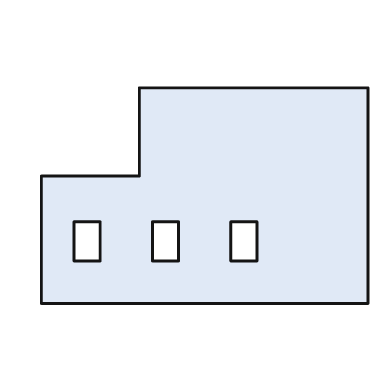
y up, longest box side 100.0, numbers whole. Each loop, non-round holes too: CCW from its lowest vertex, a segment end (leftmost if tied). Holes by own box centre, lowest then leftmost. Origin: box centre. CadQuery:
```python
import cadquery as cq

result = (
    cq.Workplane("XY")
    .moveTo(-50.0, -33.0)
    .lineTo(50.0, -33.0)
    .lineTo(50.0, 33.0)
    .lineTo(-20.0, 33.0)
    .lineTo(-20.0, 6.0)
    .lineTo(-50.0, 6.0)
    .close()
    .moveTo(-40.0, -20.0)
    .lineTo(-32.0, -20.0)
    .lineTo(-32.0, -8.0)
    .lineTo(-40.0, -8.0)
    .close()
    .moveTo(-16.0, -20.0)
    .lineTo(-8.0, -20.0)
    .lineTo(-8.0, -8.0)
    .lineTo(-16.0, -8.0)
    .close()
    .moveTo(8.0, -20.0)
    .lineTo(16.0, -20.0)
    .lineTo(16.0, -8.0)
    .lineTo(8.0, -8.0)
    .close()
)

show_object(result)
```